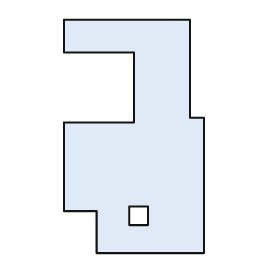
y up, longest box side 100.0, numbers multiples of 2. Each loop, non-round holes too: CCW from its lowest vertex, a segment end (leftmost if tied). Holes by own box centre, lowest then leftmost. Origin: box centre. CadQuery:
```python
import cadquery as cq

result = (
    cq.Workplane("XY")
    .moveTo(-16.0, -50.0)
    .lineTo(30.0, -50.0)
    .lineTo(30.0, 8.0)
    .lineTo(24.0, 8.0)
    .lineTo(24.0, 50.0)
    .lineTo(-30.0, 50.0)
    .lineTo(-30.0, 36.0)
    .lineTo(0.0, 36.0)
    .lineTo(0.0, 6.0)
    .lineTo(-30.0, 6.0)
    .lineTo(-30.0, -32.0)
    .lineTo(-16.0, -32.0)
    .close()
    .moveTo(-2.0, -38.0)
    .lineTo(6.0, -38.0)
    .lineTo(6.0, -30.0)
    .lineTo(-2.0, -30.0)
    .close()
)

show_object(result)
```